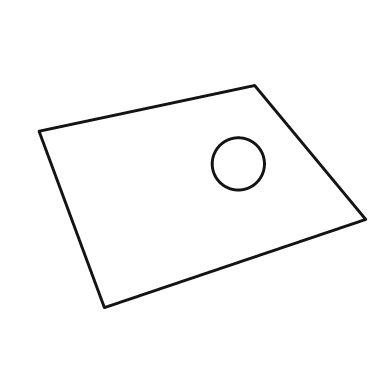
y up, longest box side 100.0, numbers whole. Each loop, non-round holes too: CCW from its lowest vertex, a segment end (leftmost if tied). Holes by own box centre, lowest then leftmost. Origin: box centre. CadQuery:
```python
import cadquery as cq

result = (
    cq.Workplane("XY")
    .moveTo(-30.0, -34.0)
    .lineTo(50.0, -7.0)
    .lineTo(16.0, 34.0)
    .lineTo(-50.0, 20.0)
    .close()
    .moveTo(11.0, 10.0)
    .circle(8.0)
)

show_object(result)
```